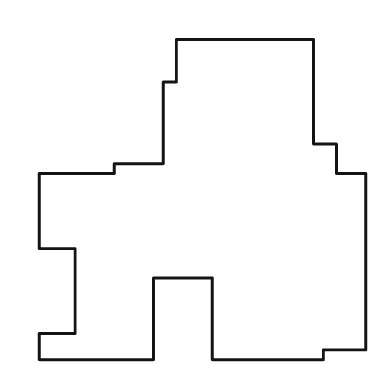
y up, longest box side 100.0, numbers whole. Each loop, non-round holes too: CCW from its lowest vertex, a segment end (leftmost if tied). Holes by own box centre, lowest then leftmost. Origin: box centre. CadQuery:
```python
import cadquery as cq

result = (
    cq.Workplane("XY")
    .moveTo(-50.0, -49.0)
    .lineTo(-15.0, -49.0)
    .lineTo(-15.0, -24.0)
    .lineTo(3.0, -24.0)
    .lineTo(3.0, -49.0)
    .lineTo(37.0, -49.0)
    .lineTo(37.0, -46.0)
    .lineTo(50.0, -46.0)
    .lineTo(50.0, 8.0)
    .lineTo(41.0, 8.0)
    .lineTo(41.0, 17.0)
    .lineTo(34.0, 17.0)
    .lineTo(34.0, 49.0)
    .lineTo(-8.0, 49.0)
    .lineTo(-8.0, 36.0)
    .lineTo(-12.0, 36.0)
    .lineTo(-12.0, 11.0)
    .lineTo(-27.0, 11.0)
    .lineTo(-27.0, 8.0)
    .lineTo(-50.0, 8.0)
    .lineTo(-50.0, -15.0)
    .lineTo(-39.0, -15.0)
    .lineTo(-39.0, -41.0)
    .lineTo(-50.0, -41.0)
    .close()
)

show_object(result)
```